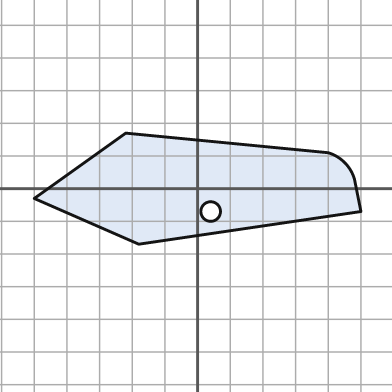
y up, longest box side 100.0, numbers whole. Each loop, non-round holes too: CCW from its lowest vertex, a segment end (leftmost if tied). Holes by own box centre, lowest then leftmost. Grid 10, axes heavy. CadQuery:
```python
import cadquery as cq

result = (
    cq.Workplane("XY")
    .moveTo(-18.0, -17.0)
    .lineTo(50.0, -7.0)
    .lineTo(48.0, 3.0)
    .threePointArc((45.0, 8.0), (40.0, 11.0))
    .lineTo(-22.0, 17.0)
    .lineTo(-50.0, -3.0)
    .close()
    .moveTo(4.0, -7.0)
    .circle(3.0)
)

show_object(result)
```